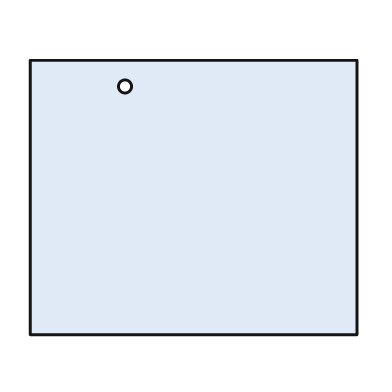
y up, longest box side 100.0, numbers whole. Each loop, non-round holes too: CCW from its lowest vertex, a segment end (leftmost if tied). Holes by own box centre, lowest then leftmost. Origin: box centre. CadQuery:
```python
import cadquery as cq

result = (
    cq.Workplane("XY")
    .moveTo(-50.0, -42.0)
    .lineTo(50.0, -42.0)
    .lineTo(50.0, 42.0)
    .lineTo(-50.0, 42.0)
    .close()
    .moveTo(-21.0, 34.0)
    .circle(2.0)
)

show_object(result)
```